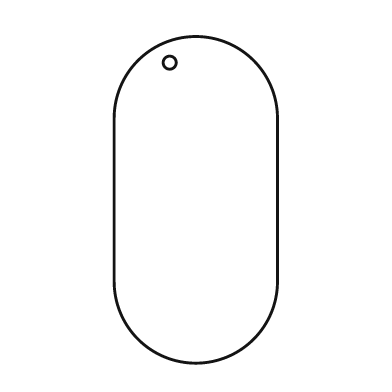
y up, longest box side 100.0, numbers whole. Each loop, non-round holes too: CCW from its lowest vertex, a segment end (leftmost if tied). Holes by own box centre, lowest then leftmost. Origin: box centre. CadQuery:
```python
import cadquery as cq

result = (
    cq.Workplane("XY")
    .moveTo(-25.0, -25.0)
    .threePointArc((0.0, -50.0), (25.0, -25.0))
    .lineTo(25.0, 25.0)
    .threePointArc((0.0, 50.0), (-25.0, 25.0))
    .close()
    .moveTo(-8.0, 42.0)
    .circle(2.0)
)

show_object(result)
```